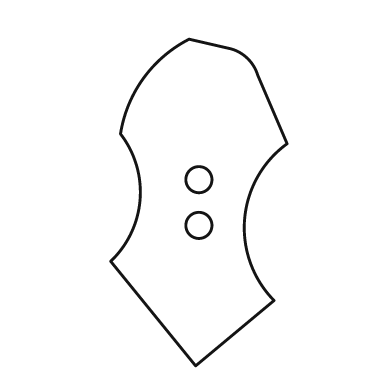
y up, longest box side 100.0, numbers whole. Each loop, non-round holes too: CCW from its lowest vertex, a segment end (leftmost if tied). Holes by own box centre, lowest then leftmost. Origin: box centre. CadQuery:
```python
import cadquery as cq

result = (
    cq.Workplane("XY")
    .moveTo(-1.0, -50.0)
    .lineTo(23.0, -30.0)
    .threePointArc((14.0, -5.0), (27.0, 18.0))
    .lineTo(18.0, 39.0)
    .threePointArc((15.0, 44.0), (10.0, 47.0))
    .lineTo(-3.0, 50.0)
    .threePointArc((-17.0, 38.0), (-24.0, 21.0))
    .threePointArc((-18.0, 1.0), (-27.0, -18.0))
    .close()
    .moveTo(0.0, -7.0)
    .circle(4.0)
    .moveTo(0.0, 7.0)
    .circle(4.0)
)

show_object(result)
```